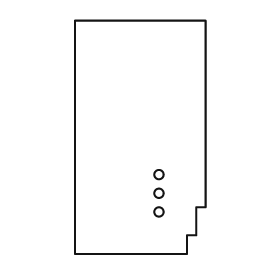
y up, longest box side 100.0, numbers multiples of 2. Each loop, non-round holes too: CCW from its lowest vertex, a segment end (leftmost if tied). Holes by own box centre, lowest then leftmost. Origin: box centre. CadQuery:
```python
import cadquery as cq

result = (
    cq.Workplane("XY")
    .moveTo(-28.0, -50.0)
    .lineTo(20.0, -50.0)
    .lineTo(20.0, -42.0)
    .lineTo(24.0, -42.0)
    .lineTo(24.0, -30.0)
    .lineTo(28.0, -30.0)
    .lineTo(28.0, 50.0)
    .lineTo(-28.0, 50.0)
    .close()
    .moveTo(8.0, -32.0)
    .circle(2.0)
    .moveTo(8.0, -24.0)
    .circle(2.0)
    .moveTo(8.0, -16.0)
    .circle(2.0)
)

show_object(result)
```